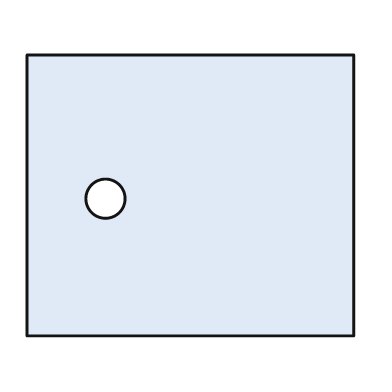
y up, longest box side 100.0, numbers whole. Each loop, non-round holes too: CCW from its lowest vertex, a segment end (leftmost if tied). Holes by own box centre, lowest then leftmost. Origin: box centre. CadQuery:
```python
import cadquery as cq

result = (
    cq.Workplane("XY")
    .moveTo(-50.0, -43.0)
    .lineTo(50.0, -43.0)
    .lineTo(50.0, 43.0)
    .lineTo(-50.0, 43.0)
    .close()
    .moveTo(-26.0, -1.0)
    .circle(6.0)
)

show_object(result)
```